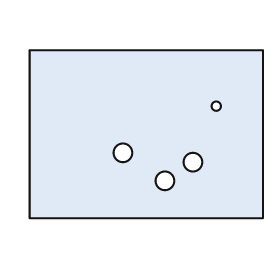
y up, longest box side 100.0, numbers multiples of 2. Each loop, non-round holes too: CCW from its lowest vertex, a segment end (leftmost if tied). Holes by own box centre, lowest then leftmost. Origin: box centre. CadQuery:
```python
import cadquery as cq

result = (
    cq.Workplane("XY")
    .moveTo(-50.0, -36.0)
    .lineTo(50.0, -36.0)
    .lineTo(50.0, 36.0)
    .lineTo(-50.0, 36.0)
    .close()
    .moveTo(8.0, -20.0)
    .circle(4.0)
    .moveTo(20.0, -12.0)
    .circle(4.0)
    .moveTo(-10.0, -8.0)
    .circle(4.0)
    .moveTo(30.0, 12.0)
    .circle(2.0)
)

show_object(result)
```